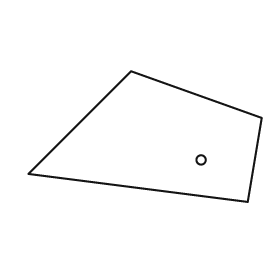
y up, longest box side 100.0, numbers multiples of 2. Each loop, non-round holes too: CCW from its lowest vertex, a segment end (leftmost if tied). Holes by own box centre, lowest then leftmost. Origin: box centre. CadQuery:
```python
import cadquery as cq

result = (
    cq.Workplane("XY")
    .moveTo(44.0, -28.0)
    .lineTo(50.0, 8.0)
    .lineTo(-6.0, 28.0)
    .lineTo(-50.0, -16.0)
    .close()
    .moveTo(24.0, -10.0)
    .circle(2.0)
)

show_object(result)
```